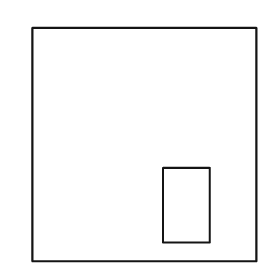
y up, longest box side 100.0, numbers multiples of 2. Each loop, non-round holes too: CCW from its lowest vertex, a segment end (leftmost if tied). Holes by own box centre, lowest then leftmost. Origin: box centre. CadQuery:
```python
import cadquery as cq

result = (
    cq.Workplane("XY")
    .moveTo(-48.0, -50.0)
    .lineTo(48.0, -50.0)
    .lineTo(48.0, 50.0)
    .lineTo(-48.0, 50.0)
    .close()
    .moveTo(8.0, -42.0)
    .lineTo(28.0, -42.0)
    .lineTo(28.0, -10.0)
    .lineTo(8.0, -10.0)
    .close()
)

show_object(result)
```